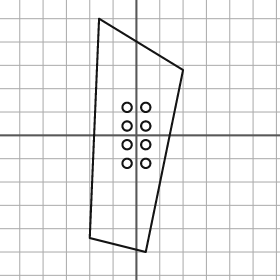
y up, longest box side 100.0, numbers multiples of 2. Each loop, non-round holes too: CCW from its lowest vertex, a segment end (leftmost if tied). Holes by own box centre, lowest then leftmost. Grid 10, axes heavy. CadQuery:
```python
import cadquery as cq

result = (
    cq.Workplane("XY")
    .moveTo(4.0, -50.0)
    .lineTo(20.0, 28.0)
    .lineTo(-16.0, 50.0)
    .lineTo(-20.0, -44.0)
    .close()
    .moveTo(-4.0, -12.0)
    .circle(2.0)
    .moveTo(4.0, -12.0)
    .circle(2.0)
    .moveTo(-4.0, -4.0)
    .circle(2.0)
    .moveTo(4.0, -4.0)
    .circle(2.0)
    .moveTo(-4.0, 4.0)
    .circle(2.0)
    .moveTo(4.0, 4.0)
    .circle(2.0)
    .moveTo(-4.0, 12.0)
    .circle(2.0)
    .moveTo(4.0, 12.0)
    .circle(2.0)
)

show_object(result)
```